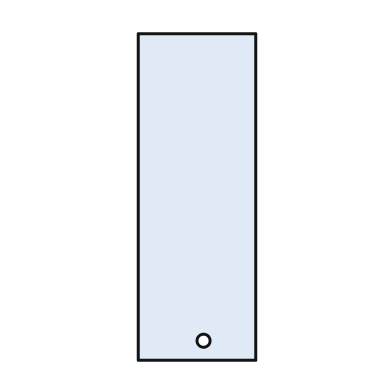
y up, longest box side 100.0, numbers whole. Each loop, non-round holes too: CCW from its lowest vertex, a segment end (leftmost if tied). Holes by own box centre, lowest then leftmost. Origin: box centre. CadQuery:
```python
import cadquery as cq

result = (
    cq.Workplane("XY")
    .moveTo(-18.0, -50.0)
    .lineTo(18.0, -50.0)
    .lineTo(18.0, 50.0)
    .lineTo(-18.0, 50.0)
    .close()
    .moveTo(2.0, -44.0)
    .circle(2.0)
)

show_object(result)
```